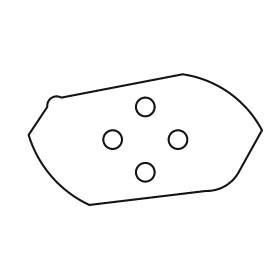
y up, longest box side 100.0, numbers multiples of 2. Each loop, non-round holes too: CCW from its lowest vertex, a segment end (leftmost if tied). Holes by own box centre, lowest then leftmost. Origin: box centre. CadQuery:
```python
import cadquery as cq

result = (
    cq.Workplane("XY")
    .moveTo(-24.0, -28.0)
    .lineTo(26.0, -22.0)
    .threePointArc((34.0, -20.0), (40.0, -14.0))
    .lineTo(50.0, 4.0)
    .threePointArc((36.0, 20.0), (16.0, 28.0))
    .lineTo(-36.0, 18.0)
    .threePointArc((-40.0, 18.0), (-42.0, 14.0))
    .lineTo(-50.0, 2.0)
    .threePointArc((-40.0, -16.0), (-24.0, -28.0))
    .close()
    .moveTo(0.0, -14.0)
    .circle(4.0)
    .moveTo(-14.0, 0.0)
    .circle(4.0)
    .moveTo(14.0, 0.0)
    .circle(4.0)
    .moveTo(0.0, 14.0)
    .circle(4.0)
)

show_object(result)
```